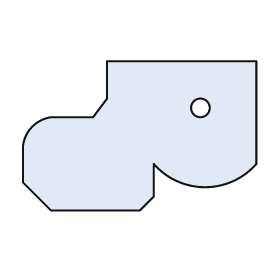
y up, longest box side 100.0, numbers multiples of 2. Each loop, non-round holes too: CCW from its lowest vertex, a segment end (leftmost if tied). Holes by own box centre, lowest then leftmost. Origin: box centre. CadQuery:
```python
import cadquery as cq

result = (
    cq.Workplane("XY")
    .moveTo(-38.0, -32.0)
    .lineTo(0.0, -32.0)
    .lineTo(6.0, -26.0)
    .lineTo(6.0, -12.0)
    .threePointArc((28.0, -22.0), (50.0, -12.0))
    .lineTo(50.0, 32.0)
    .lineTo(-14.0, 32.0)
    .lineTo(-14.0, 16.0)
    .lineTo(-20.0, 8.0)
    .lineTo(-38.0, 8.0)
    .threePointArc((-46.0, 4.0), (-50.0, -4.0))
    .lineTo(-50.0, -20.0)
    .close()
    .moveTo(26.0, 12.0)
    .circle(4.0)
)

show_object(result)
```